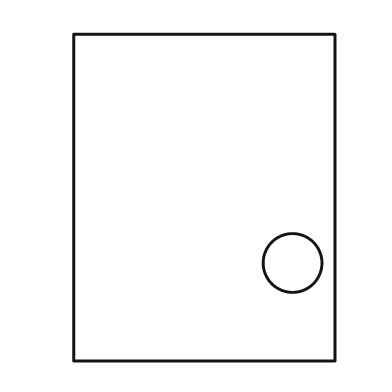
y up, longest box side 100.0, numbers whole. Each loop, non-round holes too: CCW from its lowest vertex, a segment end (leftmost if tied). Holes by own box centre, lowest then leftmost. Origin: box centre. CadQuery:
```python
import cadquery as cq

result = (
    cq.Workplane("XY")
    .moveTo(-40.0, -50.0)
    .lineTo(40.0, -50.0)
    .lineTo(40.0, 50.0)
    .lineTo(-40.0, 50.0)
    .close()
    .moveTo(27.0, -20.0)
    .circle(9.0)
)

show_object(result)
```